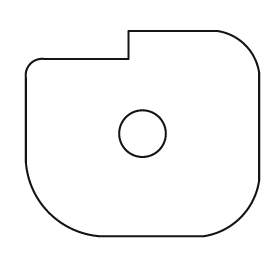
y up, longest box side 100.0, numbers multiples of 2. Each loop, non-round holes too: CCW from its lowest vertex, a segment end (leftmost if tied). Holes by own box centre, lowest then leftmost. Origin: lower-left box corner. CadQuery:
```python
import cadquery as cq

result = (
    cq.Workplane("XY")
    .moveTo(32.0, 0.0)
    .lineTo(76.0, 0.0)
    .threePointArc((92.0, 8.0), (100.0, 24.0))
    .lineTo(100.0, 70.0)
    .threePointArc((94.0, 82.0), (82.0, 88.0))
    .lineTo(44.0, 88.0)
    .lineTo(44.0, 76.0)
    .lineTo(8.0, 76.0)
    .threePointArc((2.0, 74.0), (0.0, 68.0))
    .lineTo(0.0, 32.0)
    .threePointArc((10.0, 10.0), (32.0, 0.0))
    .close()
    .moveTo(50.0, 44.0)
    .circle(10.0)
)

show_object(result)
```